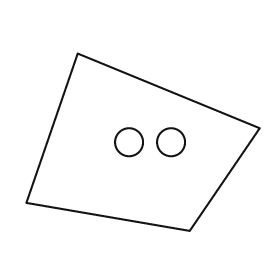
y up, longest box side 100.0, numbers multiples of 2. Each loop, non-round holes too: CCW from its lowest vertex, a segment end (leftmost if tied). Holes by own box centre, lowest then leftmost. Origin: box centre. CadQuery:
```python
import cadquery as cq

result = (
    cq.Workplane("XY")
    .moveTo(20.0, -38.0)
    .lineTo(50.0, 6.0)
    .lineTo(-28.0, 38.0)
    .lineTo(-50.0, -26.0)
    .close()
    .moveTo(-6.0, 0.0)
    .circle(6.0)
    .moveTo(12.0, 0.0)
    .circle(6.0)
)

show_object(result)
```